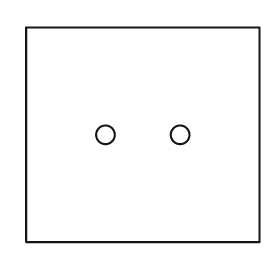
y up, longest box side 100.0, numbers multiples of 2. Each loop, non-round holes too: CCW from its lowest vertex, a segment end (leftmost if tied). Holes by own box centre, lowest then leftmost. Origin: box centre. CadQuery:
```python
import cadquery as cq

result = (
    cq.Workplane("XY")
    .moveTo(-50.0, -46.0)
    .lineTo(50.0, -46.0)
    .lineTo(50.0, 46.0)
    .lineTo(-50.0, 46.0)
    .close()
    .moveTo(-16.0, 0.0)
    .circle(4.0)
    .moveTo(16.0, 0.0)
    .circle(4.0)
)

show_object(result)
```